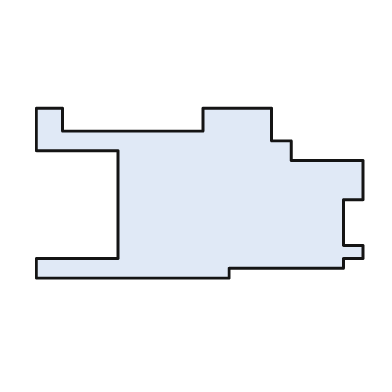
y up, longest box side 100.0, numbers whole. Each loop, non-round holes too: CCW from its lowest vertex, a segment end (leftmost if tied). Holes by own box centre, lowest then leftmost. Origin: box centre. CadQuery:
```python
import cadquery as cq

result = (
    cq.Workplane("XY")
    .moveTo(-50.0, -26.0)
    .lineTo(9.0, -26.0)
    .lineTo(9.0, -23.0)
    .lineTo(44.0, -23.0)
    .lineTo(44.0, -20.0)
    .lineTo(50.0, -20.0)
    .lineTo(50.0, -16.0)
    .lineTo(44.0, -16.0)
    .lineTo(44.0, -2.0)
    .lineTo(50.0, -2.0)
    .lineTo(50.0, 10.0)
    .lineTo(28.0, 10.0)
    .lineTo(28.0, 16.0)
    .lineTo(22.0, 16.0)
    .lineTo(22.0, 26.0)
    .lineTo(1.0, 26.0)
    .lineTo(1.0, 19.0)
    .lineTo(-42.0, 19.0)
    .lineTo(-42.0, 26.0)
    .lineTo(-50.0, 26.0)
    .lineTo(-50.0, 13.0)
    .lineTo(-25.0, 13.0)
    .lineTo(-25.0, -20.0)
    .lineTo(-50.0, -20.0)
    .close()
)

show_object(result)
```